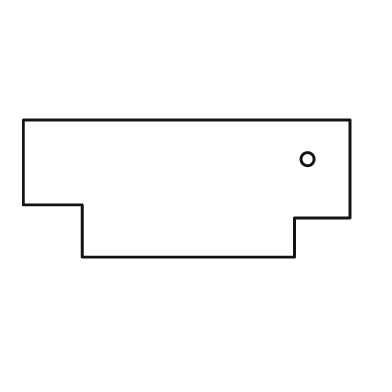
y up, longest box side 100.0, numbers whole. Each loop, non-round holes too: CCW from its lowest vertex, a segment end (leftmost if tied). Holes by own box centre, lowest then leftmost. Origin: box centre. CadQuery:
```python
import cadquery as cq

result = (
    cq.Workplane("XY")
    .moveTo(-32.0, -21.0)
    .lineTo(33.0, -21.0)
    .lineTo(33.0, -9.0)
    .lineTo(50.0, -9.0)
    .lineTo(50.0, 21.0)
    .lineTo(-50.0, 21.0)
    .lineTo(-50.0, -5.0)
    .lineTo(-32.0, -5.0)
    .close()
    .moveTo(37.0, 9.0)
    .circle(2.0)
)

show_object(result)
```